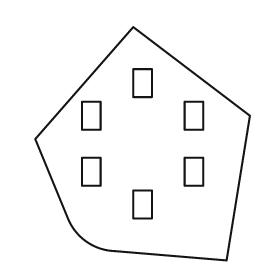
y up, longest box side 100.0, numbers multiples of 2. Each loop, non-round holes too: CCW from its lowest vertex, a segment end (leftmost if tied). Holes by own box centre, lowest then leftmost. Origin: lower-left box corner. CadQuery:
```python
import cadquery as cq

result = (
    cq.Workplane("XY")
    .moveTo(82.0, 0.0)
    .lineTo(92.0, 62.0)
    .lineTo(42.0, 100.0)
    .lineTo(0.0, 52.0)
    .lineTo(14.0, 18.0)
    .threePointArc((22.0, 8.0), (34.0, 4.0))
    .close()
    .moveTo(42.0, 18.0)
    .lineTo(50.0, 18.0)
    .lineTo(50.0, 30.0)
    .lineTo(42.0, 30.0)
    .close()
    .moveTo(20.0, 32.0)
    .lineTo(28.0, 32.0)
    .lineTo(28.0, 44.0)
    .lineTo(20.0, 44.0)
    .close()
    .moveTo(64.0, 32.0)
    .lineTo(72.0, 32.0)
    .lineTo(72.0, 44.0)
    .lineTo(64.0, 44.0)
    .close()
    .moveTo(20.0, 56.0)
    .lineTo(28.0, 56.0)
    .lineTo(28.0, 68.0)
    .lineTo(20.0, 68.0)
    .close()
    .moveTo(64.0, 56.0)
    .lineTo(72.0, 56.0)
    .lineTo(72.0, 68.0)
    .lineTo(64.0, 68.0)
    .close()
    .moveTo(42.0, 70.0)
    .lineTo(50.0, 70.0)
    .lineTo(50.0, 82.0)
    .lineTo(42.0, 82.0)
    .close()
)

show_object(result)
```